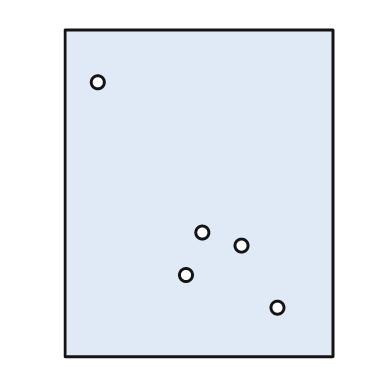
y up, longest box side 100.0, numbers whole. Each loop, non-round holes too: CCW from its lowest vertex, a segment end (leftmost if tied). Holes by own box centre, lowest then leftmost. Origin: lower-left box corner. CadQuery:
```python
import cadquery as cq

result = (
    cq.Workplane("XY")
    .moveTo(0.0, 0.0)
    .lineTo(82.0, 0.0)
    .lineTo(82.0, 100.0)
    .lineTo(0.0, 100.0)
    .close()
    .moveTo(65.0, 15.0)
    .circle(2.0)
    .moveTo(37.0, 25.0)
    .circle(2.0)
    .moveTo(54.0, 34.0)
    .circle(2.0)
    .moveTo(42.0, 38.0)
    .circle(2.0)
    .moveTo(10.0, 84.0)
    .circle(2.0)
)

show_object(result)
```